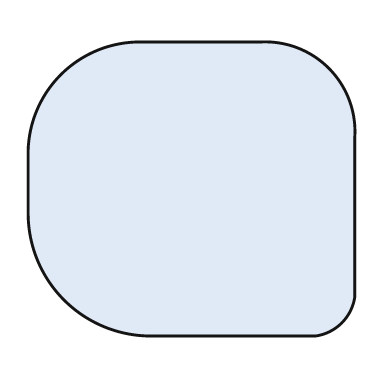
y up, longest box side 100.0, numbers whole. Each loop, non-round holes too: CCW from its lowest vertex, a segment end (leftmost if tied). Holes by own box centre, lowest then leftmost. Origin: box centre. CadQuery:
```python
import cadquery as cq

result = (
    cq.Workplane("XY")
    .moveTo(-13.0, -45.0)
    .lineTo(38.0, -45.0)
    .threePointArc((46.0, -41.0), (50.0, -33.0))
    .lineTo(50.0, 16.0)
    .threePointArc((42.0, 37.0), (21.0, 45.0))
    .lineTo(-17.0, 45.0)
    .threePointArc((-40.0, 35.0), (-50.0, 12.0))
    .lineTo(-50.0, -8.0)
    .threePointArc((-39.0, -34.0), (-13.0, -45.0))
    .close()
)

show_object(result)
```